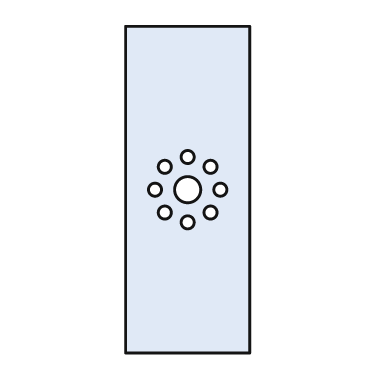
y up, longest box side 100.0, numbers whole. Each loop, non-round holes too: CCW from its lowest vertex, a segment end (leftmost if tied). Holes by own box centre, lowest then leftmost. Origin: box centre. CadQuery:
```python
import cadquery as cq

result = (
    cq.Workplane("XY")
    .moveTo(-19.0, -50.0)
    .lineTo(19.0, -50.0)
    .lineTo(19.0, 50.0)
    .lineTo(-19.0, 50.0)
    .close()
    .moveTo(0.0, -10.0)
    .circle(2.0)
    .moveTo(-7.0, -7.0)
    .circle(2.0)
    .moveTo(7.0, -7.0)
    .circle(2.0)
    .moveTo(-10.0, 0.0)
    .circle(2.0)
    .moveTo(0.0, 0.0)
    .circle(4.0)
    .moveTo(10.0, 0.0)
    .circle(2.0)
    .moveTo(-7.0, 7.0)
    .circle(2.0)
    .moveTo(7.0, 7.0)
    .circle(2.0)
    .moveTo(0.0, 10.0)
    .circle(2.0)
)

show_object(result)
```